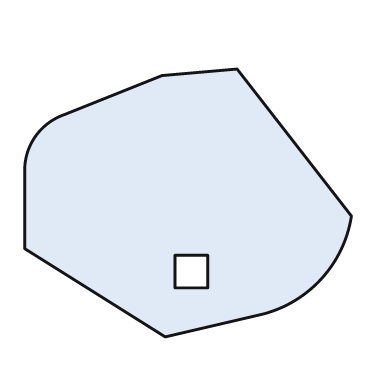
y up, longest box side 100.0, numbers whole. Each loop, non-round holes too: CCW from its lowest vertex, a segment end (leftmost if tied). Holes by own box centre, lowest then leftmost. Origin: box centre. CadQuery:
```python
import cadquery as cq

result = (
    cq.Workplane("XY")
    .moveTo(-7.0, -41.0)
    .lineTo(23.0, -34.0)
    .threePointArc((41.0, -23.0), (50.0, -4.0))
    .lineTo(15.0, 41.0)
    .lineTo(-8.0, 39.0)
    .lineTo(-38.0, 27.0)
    .threePointArc((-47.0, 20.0), (-50.0, 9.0))
    .lineTo(-50.0, -14.0)
    .close()
    .moveTo(-4.0, -26.0)
    .lineTo(6.0, -26.0)
    .lineTo(6.0, -16.0)
    .lineTo(-4.0, -16.0)
    .close()
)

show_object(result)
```